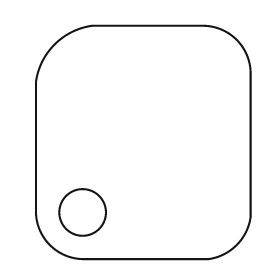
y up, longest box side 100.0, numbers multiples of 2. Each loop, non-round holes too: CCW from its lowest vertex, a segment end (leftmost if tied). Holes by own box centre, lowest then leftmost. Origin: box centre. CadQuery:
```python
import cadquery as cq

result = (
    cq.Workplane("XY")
    .moveTo(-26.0, -50.0)
    .lineTo(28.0, -50.0)
    .threePointArc((40.0, -44.0), (46.0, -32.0))
    .lineTo(46.0, 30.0)
    .threePointArc((40.0, 44.0), (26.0, 50.0))
    .lineTo(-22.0, 50.0)
    .threePointArc((-38.0, 42.0), (-46.0, 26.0))
    .lineTo(-46.0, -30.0)
    .threePointArc((-40.0, -44.0), (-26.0, -50.0))
    .close()
    .moveTo(-26.0, -30.0)
    .circle(10.0)
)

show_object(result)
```